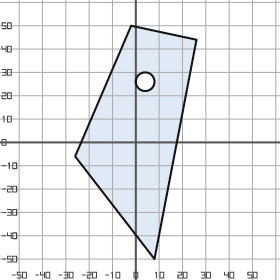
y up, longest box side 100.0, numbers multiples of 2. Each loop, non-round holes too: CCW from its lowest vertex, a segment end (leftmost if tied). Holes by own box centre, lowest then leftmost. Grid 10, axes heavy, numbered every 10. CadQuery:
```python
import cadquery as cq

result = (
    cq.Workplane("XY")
    .moveTo(8.0, -50.0)
    .lineTo(26.0, 44.0)
    .lineTo(-2.0, 50.0)
    .lineTo(-26.0, -6.0)
    .close()
    .moveTo(4.0, 26.0)
    .circle(4.0)
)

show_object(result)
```